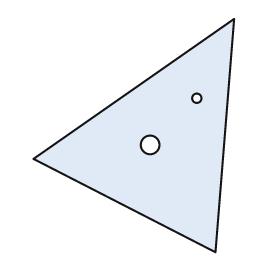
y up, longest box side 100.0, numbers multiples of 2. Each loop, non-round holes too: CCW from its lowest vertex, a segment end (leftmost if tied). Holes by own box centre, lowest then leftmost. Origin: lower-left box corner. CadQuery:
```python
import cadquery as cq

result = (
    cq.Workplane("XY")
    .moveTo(78.0, 0.0)
    .lineTo(86.0, 100.0)
    .lineTo(0.0, 40.0)
    .close()
    .moveTo(50.0, 46.0)
    .circle(4.0)
    .moveTo(70.0, 66.0)
    .circle(2.0)
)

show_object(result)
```